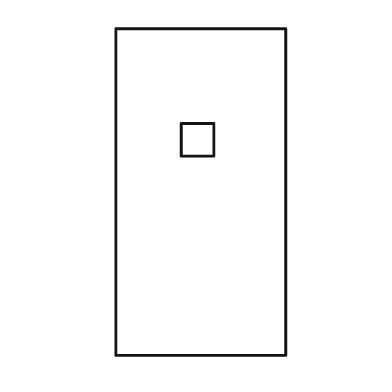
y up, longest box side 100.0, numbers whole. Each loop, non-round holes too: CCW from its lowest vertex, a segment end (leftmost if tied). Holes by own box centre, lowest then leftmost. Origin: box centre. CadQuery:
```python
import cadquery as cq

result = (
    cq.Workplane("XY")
    .moveTo(-26.0, -50.0)
    .lineTo(26.0, -50.0)
    .lineTo(26.0, 50.0)
    .lineTo(-26.0, 50.0)
    .close()
    .moveTo(-6.0, 11.0)
    .lineTo(4.0, 11.0)
    .lineTo(4.0, 21.0)
    .lineTo(-6.0, 21.0)
    .close()
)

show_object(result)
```